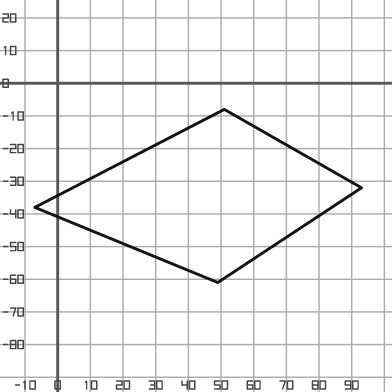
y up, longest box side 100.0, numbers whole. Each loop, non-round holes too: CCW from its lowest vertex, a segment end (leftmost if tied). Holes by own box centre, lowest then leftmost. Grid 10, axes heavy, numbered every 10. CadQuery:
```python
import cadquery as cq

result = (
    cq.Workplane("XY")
    .moveTo(49.0, -61.0)
    .lineTo(93.0, -32.0)
    .lineTo(51.0, -8.0)
    .lineTo(-7.0, -38.0)
    .close()
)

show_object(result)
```